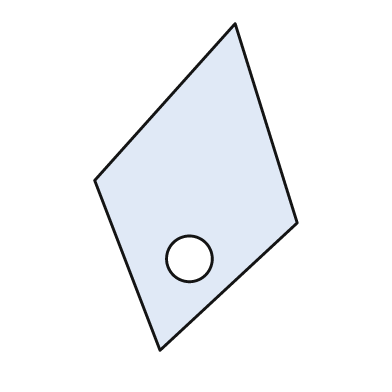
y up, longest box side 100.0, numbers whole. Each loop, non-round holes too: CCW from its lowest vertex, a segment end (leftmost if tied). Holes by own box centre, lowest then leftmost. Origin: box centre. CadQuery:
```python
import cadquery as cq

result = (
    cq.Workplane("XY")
    .moveTo(-11.0, -50.0)
    .lineTo(31.0, -11.0)
    .lineTo(12.0, 50.0)
    .lineTo(-31.0, 2.0)
    .close()
    .moveTo(-2.0, -22.0)
    .circle(7.0)
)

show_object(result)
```